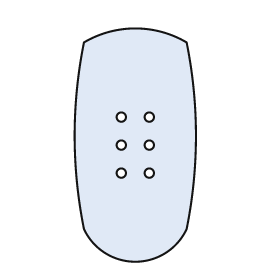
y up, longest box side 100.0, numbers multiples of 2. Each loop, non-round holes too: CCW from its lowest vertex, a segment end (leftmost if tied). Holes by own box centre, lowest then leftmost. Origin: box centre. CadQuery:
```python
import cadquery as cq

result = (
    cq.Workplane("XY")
    .moveTo(-22.0, -36.0)
    .threePointArc((0.0, -50.0), (22.0, -36.0))
    .threePointArc((26.0, 4.0), (22.0, 44.0))
    .threePointArc((0.0, 50.0), (-22.0, 44.0))
    .threePointArc((-26.0, 4.0), (-22.0, -36.0))
    .close()
    .moveTo(-6.0, -12.0)
    .circle(2.0)
    .moveTo(6.0, -12.0)
    .circle(2.0)
    .moveTo(-6.0, 0.0)
    .circle(2.0)
    .moveTo(6.0, 0.0)
    .circle(2.0)
    .moveTo(-6.0, 12.0)
    .circle(2.0)
    .moveTo(6.0, 12.0)
    .circle(2.0)
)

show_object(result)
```